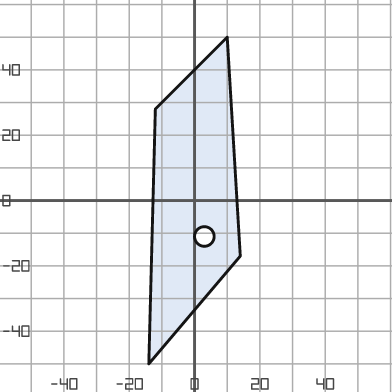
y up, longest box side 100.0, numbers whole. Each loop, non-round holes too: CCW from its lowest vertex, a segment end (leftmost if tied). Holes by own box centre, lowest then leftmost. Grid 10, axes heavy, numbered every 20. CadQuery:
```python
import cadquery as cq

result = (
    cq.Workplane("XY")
    .moveTo(-14.0, -50.0)
    .lineTo(14.0, -17.0)
    .lineTo(10.0, 50.0)
    .lineTo(-12.0, 28.0)
    .close()
    .moveTo(3.0, -11.0)
    .circle(3.0)
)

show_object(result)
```